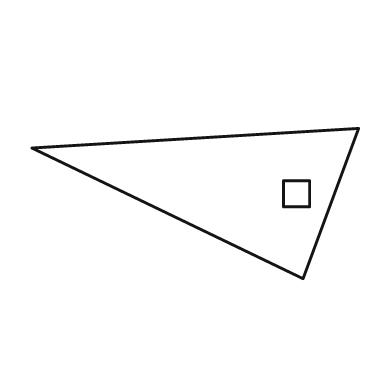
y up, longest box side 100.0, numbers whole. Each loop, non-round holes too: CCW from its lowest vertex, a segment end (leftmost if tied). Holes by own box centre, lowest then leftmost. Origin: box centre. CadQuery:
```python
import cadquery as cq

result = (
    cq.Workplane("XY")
    .moveTo(33.0, -23.0)
    .lineTo(50.0, 23.0)
    .lineTo(-50.0, 17.0)
    .close()
    .moveTo(27.0, -1.0)
    .lineTo(35.0, -1.0)
    .lineTo(35.0, 7.0)
    .lineTo(27.0, 7.0)
    .close()
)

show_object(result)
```